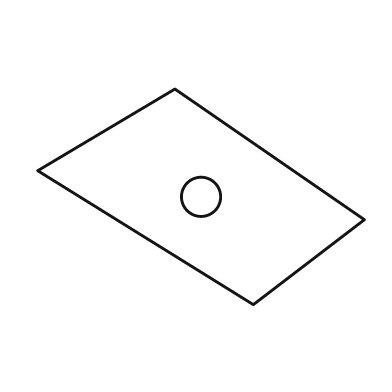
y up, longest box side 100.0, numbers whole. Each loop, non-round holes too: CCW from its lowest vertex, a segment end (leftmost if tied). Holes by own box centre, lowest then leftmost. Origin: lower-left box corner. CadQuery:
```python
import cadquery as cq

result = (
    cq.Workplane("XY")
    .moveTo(66.0, 0.0)
    .lineTo(100.0, 26.0)
    .lineTo(42.0, 66.0)
    .lineTo(0.0, 41.0)
    .close()
    .moveTo(50.0, 33.0)
    .circle(6.0)
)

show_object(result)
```